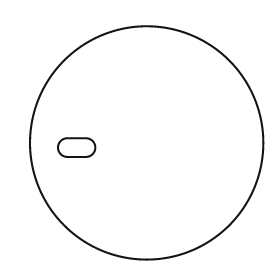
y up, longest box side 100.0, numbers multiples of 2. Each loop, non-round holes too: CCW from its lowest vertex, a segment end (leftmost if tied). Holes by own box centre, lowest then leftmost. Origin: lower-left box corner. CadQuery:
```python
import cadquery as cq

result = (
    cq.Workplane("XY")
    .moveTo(50.0, 50.0)
    .circle(50.0)
    .moveTo(16.0, 44.0)
    .lineTo(24.0, 44.0)
    .threePointArc((28.0, 48.0), (24.0, 52.0))
    .lineTo(16.0, 52.0)
    .threePointArc((12.0, 48.0), (16.0, 44.0))
    .close()
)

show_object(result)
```